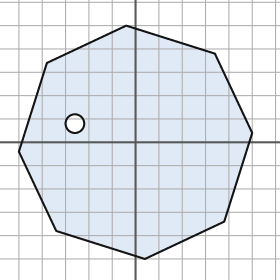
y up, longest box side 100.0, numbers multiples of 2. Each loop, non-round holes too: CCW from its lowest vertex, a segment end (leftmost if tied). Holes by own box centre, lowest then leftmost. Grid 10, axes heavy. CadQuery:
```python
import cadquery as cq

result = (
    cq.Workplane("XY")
    .moveTo(4.0, -50.0)
    .lineTo(38.0, -34.0)
    .lineTo(50.0, 4.0)
    .lineTo(34.0, 38.0)
    .lineTo(-4.0, 50.0)
    .lineTo(-38.0, 34.0)
    .lineTo(-50.0, -4.0)
    .lineTo(-34.0, -38.0)
    .close()
    .moveTo(-26.0, 8.0)
    .circle(4.0)
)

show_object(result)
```